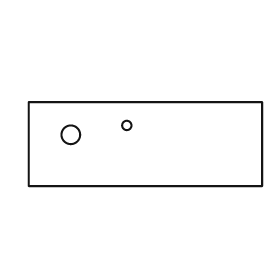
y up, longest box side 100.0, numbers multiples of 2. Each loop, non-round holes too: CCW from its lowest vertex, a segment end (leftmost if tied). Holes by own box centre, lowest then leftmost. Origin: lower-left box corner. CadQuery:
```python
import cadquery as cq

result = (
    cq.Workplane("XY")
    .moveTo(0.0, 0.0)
    .lineTo(100.0, 0.0)
    .lineTo(100.0, 36.0)
    .lineTo(0.0, 36.0)
    .close()
    .moveTo(18.0, 22.0)
    .circle(4.0)
    .moveTo(42.0, 26.0)
    .circle(2.0)
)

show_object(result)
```